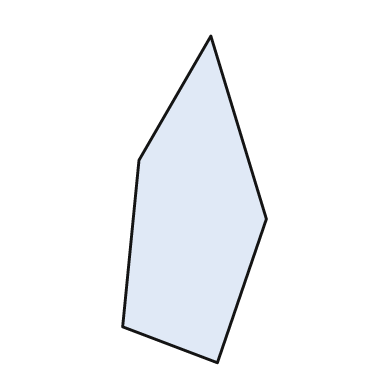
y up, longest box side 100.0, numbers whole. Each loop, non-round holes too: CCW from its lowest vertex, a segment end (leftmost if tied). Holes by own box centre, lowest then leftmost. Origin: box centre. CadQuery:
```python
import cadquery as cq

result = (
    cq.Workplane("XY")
    .moveTo(7.0, -50.0)
    .lineTo(22.0, -6.0)
    .lineTo(5.0, 50.0)
    .lineTo(-17.0, 12.0)
    .lineTo(-22.0, -39.0)
    .close()
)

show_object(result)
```